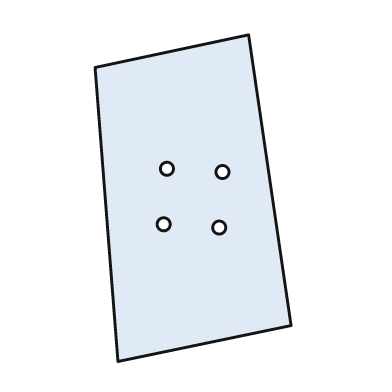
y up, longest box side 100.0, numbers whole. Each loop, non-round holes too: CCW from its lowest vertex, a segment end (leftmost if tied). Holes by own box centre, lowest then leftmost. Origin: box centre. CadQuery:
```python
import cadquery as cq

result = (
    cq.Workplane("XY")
    .moveTo(-23.0, -50.0)
    .lineTo(30.0, -39.0)
    .lineTo(17.0, 50.0)
    .lineTo(-30.0, 40.0)
    .close()
    .moveTo(8.0, -9.0)
    .circle(2.0)
    .moveTo(-9.0, -8.0)
    .circle(2.0)
    .moveTo(9.0, 8.0)
    .circle(2.0)
    .moveTo(-8.0, 9.0)
    .circle(2.0)
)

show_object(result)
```